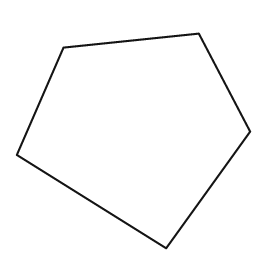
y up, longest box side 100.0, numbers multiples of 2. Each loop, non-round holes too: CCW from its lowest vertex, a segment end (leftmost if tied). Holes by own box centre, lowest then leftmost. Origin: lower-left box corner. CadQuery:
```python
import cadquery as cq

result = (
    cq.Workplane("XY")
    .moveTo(64.0, 0.0)
    .lineTo(100.0, 50.0)
    .lineTo(78.0, 92.0)
    .lineTo(20.0, 86.0)
    .lineTo(0.0, 40.0)
    .close()
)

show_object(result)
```